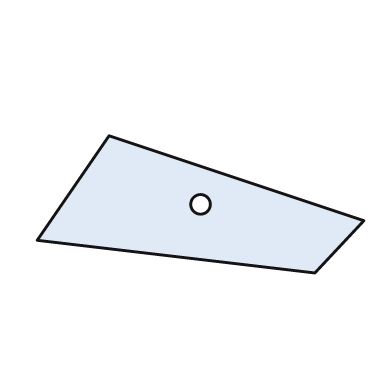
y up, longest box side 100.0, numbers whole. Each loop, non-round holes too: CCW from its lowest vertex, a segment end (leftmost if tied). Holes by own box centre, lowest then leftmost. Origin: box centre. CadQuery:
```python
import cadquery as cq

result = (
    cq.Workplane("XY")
    .moveTo(35.0, -21.0)
    .lineTo(50.0, -5.0)
    .lineTo(-28.0, 21.0)
    .lineTo(-50.0, -11.0)
    .close()
    .moveTo(0.0, 0.0)
    .circle(3.0)
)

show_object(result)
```